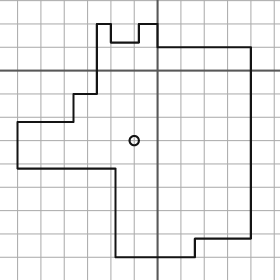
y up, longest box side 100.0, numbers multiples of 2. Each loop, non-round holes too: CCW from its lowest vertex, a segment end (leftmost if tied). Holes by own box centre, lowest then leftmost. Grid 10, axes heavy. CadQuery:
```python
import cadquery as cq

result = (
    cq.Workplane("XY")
    .moveTo(-18.0, -80.0)
    .lineTo(16.0, -80.0)
    .lineTo(16.0, -72.0)
    .lineTo(40.0, -72.0)
    .lineTo(40.0, 10.0)
    .lineTo(0.0, 10.0)
    .lineTo(0.0, 20.0)
    .lineTo(-8.0, 20.0)
    .lineTo(-8.0, 12.0)
    .lineTo(-20.0, 12.0)
    .lineTo(-20.0, 20.0)
    .lineTo(-26.0, 20.0)
    .lineTo(-26.0, -10.0)
    .lineTo(-36.0, -10.0)
    .lineTo(-36.0, -22.0)
    .lineTo(-60.0, -22.0)
    .lineTo(-60.0, -42.0)
    .lineTo(-18.0, -42.0)
    .close()
    .moveTo(-10.0, -30.0)
    .circle(2.0)
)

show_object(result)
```